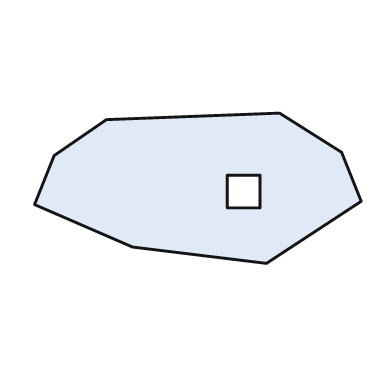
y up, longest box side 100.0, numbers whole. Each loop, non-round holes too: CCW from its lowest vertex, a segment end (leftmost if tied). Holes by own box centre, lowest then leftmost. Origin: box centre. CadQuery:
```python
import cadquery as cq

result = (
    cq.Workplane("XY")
    .moveTo(21.0, -23.0)
    .lineTo(50.0, -4.0)
    .lineTo(44.0, 11.0)
    .lineTo(25.0, 23.0)
    .lineTo(-28.0, 21.0)
    .lineTo(-44.0, 10.0)
    .lineTo(-50.0, -5.0)
    .lineTo(-20.0, -18.0)
    .close()
    .moveTo(9.0, -6.0)
    .lineTo(19.0, -6.0)
    .lineTo(19.0, 4.0)
    .lineTo(9.0, 4.0)
    .close()
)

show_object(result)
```